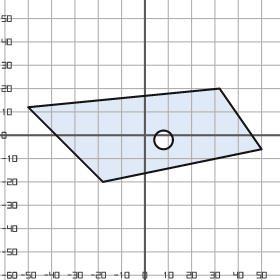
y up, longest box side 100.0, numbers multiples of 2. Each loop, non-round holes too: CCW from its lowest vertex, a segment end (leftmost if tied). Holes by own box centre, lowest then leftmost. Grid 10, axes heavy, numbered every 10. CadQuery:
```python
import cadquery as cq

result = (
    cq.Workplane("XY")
    .moveTo(-18.0, -20.0)
    .lineTo(50.0, -6.0)
    .lineTo(32.0, 20.0)
    .lineTo(-50.0, 12.0)
    .close()
    .moveTo(8.0, -2.0)
    .circle(4.0)
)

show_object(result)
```